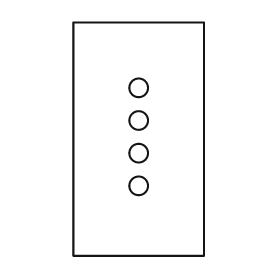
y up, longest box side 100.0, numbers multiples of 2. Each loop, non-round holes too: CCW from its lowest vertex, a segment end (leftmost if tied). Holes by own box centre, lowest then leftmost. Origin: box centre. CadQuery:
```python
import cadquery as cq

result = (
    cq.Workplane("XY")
    .moveTo(-28.0, -50.0)
    .lineTo(28.0, -50.0)
    .lineTo(28.0, 50.0)
    .lineTo(-28.0, 50.0)
    .close()
    .moveTo(0.0, -20.0)
    .circle(4.0)
    .moveTo(0.0, -6.0)
    .circle(4.0)
    .moveTo(0.0, 8.0)
    .circle(4.0)
    .moveTo(0.0, 22.0)
    .circle(4.0)
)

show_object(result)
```